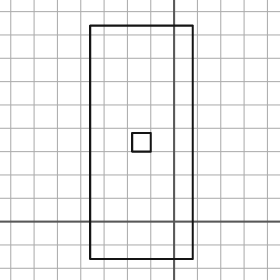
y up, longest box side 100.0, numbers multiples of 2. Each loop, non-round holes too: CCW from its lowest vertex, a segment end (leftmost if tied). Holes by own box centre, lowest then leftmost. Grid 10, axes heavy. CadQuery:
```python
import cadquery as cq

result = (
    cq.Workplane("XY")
    .moveTo(-36.0, -16.0)
    .lineTo(8.0, -16.0)
    .lineTo(8.0, 84.0)
    .lineTo(-36.0, 84.0)
    .close()
    .moveTo(-18.0, 30.0)
    .lineTo(-10.0, 30.0)
    .lineTo(-10.0, 38.0)
    .lineTo(-18.0, 38.0)
    .close()
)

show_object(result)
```